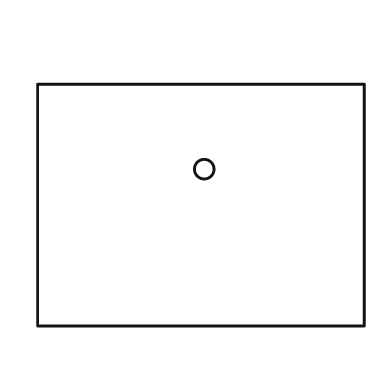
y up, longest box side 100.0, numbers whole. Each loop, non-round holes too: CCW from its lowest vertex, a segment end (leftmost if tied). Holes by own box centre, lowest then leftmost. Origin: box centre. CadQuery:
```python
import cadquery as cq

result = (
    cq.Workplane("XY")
    .moveTo(-50.0, -37.0)
    .lineTo(50.0, -37.0)
    .lineTo(50.0, 37.0)
    .lineTo(-50.0, 37.0)
    .close()
    .moveTo(1.0, 11.0)
    .circle(3.0)
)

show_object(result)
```